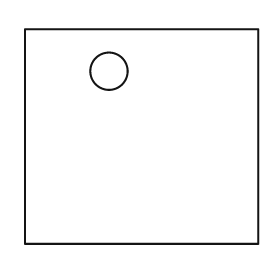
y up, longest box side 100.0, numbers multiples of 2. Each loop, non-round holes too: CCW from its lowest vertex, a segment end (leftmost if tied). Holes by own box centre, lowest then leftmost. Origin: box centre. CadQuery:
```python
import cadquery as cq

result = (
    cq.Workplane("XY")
    .moveTo(-50.0, -46.0)
    .lineTo(50.0, -46.0)
    .lineTo(50.0, 46.0)
    .lineTo(-50.0, 46.0)
    .close()
    .moveTo(-14.0, 28.0)
    .circle(8.0)
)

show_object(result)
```